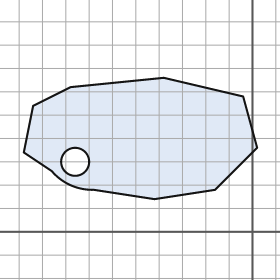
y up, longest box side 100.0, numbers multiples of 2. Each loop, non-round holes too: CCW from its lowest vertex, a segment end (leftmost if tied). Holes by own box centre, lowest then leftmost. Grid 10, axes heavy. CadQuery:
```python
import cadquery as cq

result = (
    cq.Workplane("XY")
    .moveTo(-42.0, 14.0)
    .lineTo(-16.0, 18.0)
    .lineTo(2.0, 36.0)
    .lineTo(-4.0, 58.0)
    .lineTo(-38.0, 66.0)
    .lineTo(-78.0, 62.0)
    .lineTo(-94.0, 54.0)
    .lineTo(-98.0, 34.0)
    .lineTo(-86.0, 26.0)
    .threePointArc((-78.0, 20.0), (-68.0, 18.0))
    .close()
    .moveTo(-76.0, 30.0)
    .circle(6.0)
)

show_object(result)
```